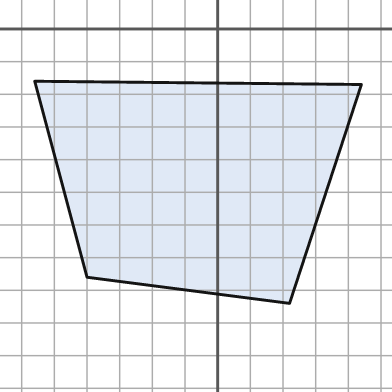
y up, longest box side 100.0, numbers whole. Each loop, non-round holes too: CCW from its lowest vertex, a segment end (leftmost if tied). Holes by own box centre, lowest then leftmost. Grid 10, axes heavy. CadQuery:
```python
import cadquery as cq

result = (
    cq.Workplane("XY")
    .moveTo(22.0, -84.0)
    .lineTo(44.0, -17.0)
    .lineTo(-56.0, -16.0)
    .lineTo(-40.0, -76.0)
    .close()
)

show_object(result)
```